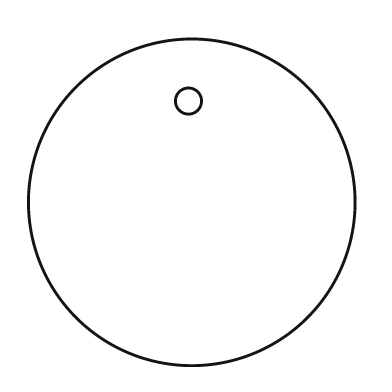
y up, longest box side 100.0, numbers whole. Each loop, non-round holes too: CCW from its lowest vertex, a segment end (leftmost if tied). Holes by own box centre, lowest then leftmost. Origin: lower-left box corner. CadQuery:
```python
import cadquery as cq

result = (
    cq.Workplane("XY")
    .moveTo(50.0, 50.0)
    .circle(50.0)
    .moveTo(49.0, 81.0)
    .circle(4.0)
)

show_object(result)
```